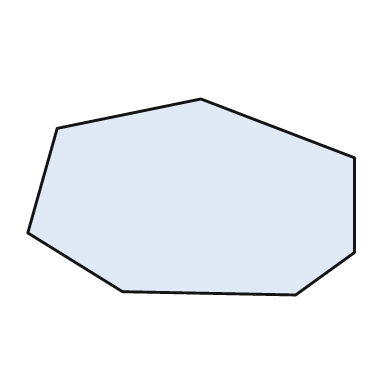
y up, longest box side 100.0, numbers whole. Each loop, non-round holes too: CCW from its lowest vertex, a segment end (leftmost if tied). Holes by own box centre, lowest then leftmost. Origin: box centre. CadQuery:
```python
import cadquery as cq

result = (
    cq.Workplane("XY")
    .moveTo(32.0, -30.0)
    .lineTo(50.0, -17.0)
    .lineTo(50.0, 12.0)
    .lineTo(3.0, 30.0)
    .lineTo(-41.0, 21.0)
    .lineTo(-50.0, -11.0)
    .lineTo(-21.0, -29.0)
    .close()
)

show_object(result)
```